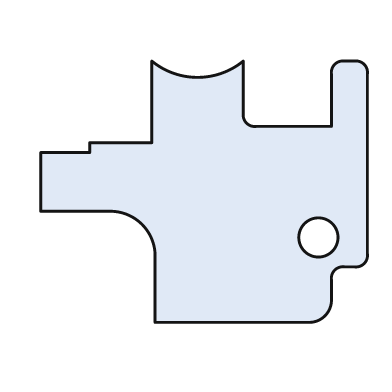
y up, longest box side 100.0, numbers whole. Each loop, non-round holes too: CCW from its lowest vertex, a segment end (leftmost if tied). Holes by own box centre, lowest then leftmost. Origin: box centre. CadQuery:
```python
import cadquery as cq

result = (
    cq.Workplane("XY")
    .moveTo(-15.0, -40.0)
    .lineTo(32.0, -40.0)
    .threePointArc((37.0, -38.0), (39.0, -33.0))
    .lineTo(39.0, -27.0)
    .threePointArc((40.0, -24.0), (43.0, -23.0))
    .lineTo(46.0, -23.0)
    .threePointArc((49.0, -22.0), (50.0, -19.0))
    .lineTo(50.0, 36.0)
    .threePointArc((49.0, 39.0), (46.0, 40.0))
    .lineTo(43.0, 40.0)
    .threePointArc((40.0, 39.0), (39.0, 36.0))
    .lineTo(39.0, 20.0)
    .lineTo(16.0, 20.0)
    .threePointArc((13.0, 21.0), (12.0, 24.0))
    .lineTo(12.0, 40.0)
    .threePointArc((-2.0, 35.0), (-16.0, 40.0))
    .lineTo(-16.0, 15.0)
    .lineTo(-35.0, 15.0)
    .lineTo(-35.0, 12.0)
    .lineTo(-50.0, 12.0)
    .lineTo(-50.0, -6.0)
    .lineTo(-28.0, -6.0)
    .threePointArc((-19.0, -10.0), (-15.0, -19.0))
    .close()
    .moveTo(35.0, -14.0)
    .circle(6.0)
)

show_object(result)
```